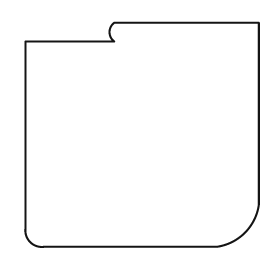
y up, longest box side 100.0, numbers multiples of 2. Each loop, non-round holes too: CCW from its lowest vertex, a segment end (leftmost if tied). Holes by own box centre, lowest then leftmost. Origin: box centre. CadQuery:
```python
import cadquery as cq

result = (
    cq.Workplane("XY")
    .moveTo(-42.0, -48.0)
    .lineTo(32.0, -48.0)
    .threePointArc((44.0, -42.0), (50.0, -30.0))
    .lineTo(50.0, 48.0)
    .lineTo(-12.0, 48.0)
    .threePointArc((-14.0, 44.0), (-12.0, 40.0))
    .lineTo(-50.0, 40.0)
    .lineTo(-50.0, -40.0)
    .threePointArc((-48.0, -46.0), (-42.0, -48.0))
    .close()
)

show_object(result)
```